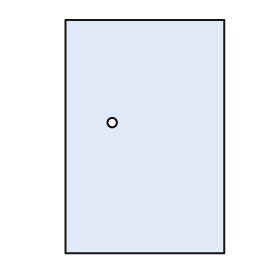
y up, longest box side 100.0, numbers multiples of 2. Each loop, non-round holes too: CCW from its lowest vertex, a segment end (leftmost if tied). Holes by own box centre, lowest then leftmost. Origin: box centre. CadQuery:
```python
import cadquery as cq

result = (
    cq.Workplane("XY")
    .moveTo(-34.0, -50.0)
    .lineTo(34.0, -50.0)
    .lineTo(34.0, 50.0)
    .lineTo(-34.0, 50.0)
    .close()
    .moveTo(-14.0, 6.0)
    .circle(2.0)
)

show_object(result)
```